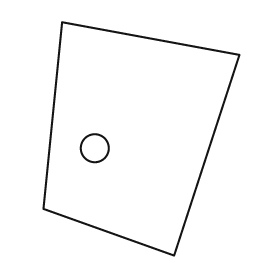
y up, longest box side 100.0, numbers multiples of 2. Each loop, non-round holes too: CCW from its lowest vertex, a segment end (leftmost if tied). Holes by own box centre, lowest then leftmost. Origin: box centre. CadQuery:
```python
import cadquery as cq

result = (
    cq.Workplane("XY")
    .moveTo(14.0, -50.0)
    .lineTo(42.0, 36.0)
    .lineTo(-34.0, 50.0)
    .lineTo(-42.0, -30.0)
    .close()
    .moveTo(-20.0, -4.0)
    .circle(6.0)
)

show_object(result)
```